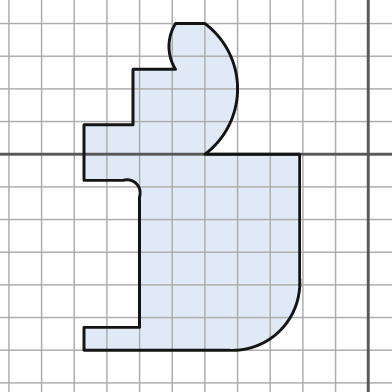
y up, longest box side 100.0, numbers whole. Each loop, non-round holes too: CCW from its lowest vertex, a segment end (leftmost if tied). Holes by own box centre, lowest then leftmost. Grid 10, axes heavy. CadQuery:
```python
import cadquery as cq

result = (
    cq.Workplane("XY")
    .moveTo(-87.0, -60.0)
    .lineTo(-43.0, -60.0)
    .threePointArc((-27.0, -54.0), (-21.0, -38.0))
    .lineTo(-21.0, 0.0)
    .lineTo(-50.0, 0.0)
    .threePointArc((-40.0, 20.0), (-50.0, 40.0))
    .lineTo(-59.0, 40.0)
    .threePointArc((-61.0, 33.0), (-59.0, 26.0))
    .lineTo(-72.0, 26.0)
    .lineTo(-72.0, 9.0)
    .lineTo(-87.0, 9.0)
    .lineTo(-87.0, -8.0)
    .lineTo(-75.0, -8.0)
    .threePointArc((-71.0, -9.0), (-70.0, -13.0))
    .lineTo(-70.0, -53.0)
    .lineTo(-87.0, -53.0)
    .close()
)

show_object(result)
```